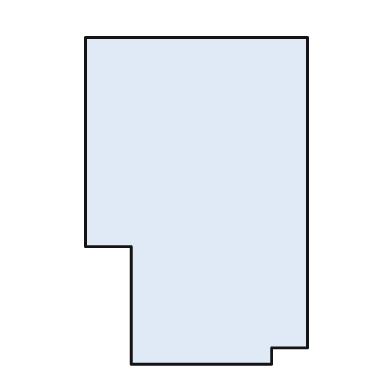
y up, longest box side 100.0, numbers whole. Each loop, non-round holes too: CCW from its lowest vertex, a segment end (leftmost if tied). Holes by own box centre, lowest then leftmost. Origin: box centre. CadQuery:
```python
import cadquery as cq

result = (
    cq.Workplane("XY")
    .moveTo(-20.0, -50.0)
    .lineTo(23.0, -50.0)
    .lineTo(23.0, -45.0)
    .lineTo(34.0, -45.0)
    .lineTo(34.0, 50.0)
    .lineTo(-34.0, 50.0)
    .lineTo(-34.0, -14.0)
    .lineTo(-20.0, -14.0)
    .close()
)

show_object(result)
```